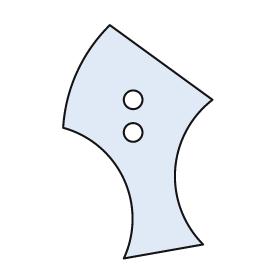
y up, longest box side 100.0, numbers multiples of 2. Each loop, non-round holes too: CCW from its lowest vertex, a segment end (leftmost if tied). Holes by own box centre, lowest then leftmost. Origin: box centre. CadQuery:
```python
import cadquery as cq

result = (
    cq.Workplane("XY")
    .moveTo(-6.0, -50.0)
    .lineTo(28.0, -44.0)
    .threePointArc((16.0, -12.0), (32.0, 18.0))
    .lineTo(-12.0, 50.0)
    .threePointArc((-26.0, 30.0), (-32.0, 6.0))
    .threePointArc((-6.0, -16.0), (-6.0, -50.0))
    .close()
    .moveTo(-2.0, 4.0)
    .circle(4.0)
    .moveTo(-2.0, 18.0)
    .circle(4.0)
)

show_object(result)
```